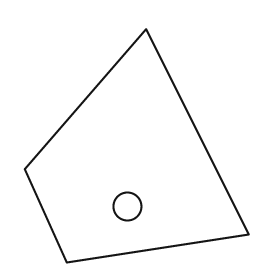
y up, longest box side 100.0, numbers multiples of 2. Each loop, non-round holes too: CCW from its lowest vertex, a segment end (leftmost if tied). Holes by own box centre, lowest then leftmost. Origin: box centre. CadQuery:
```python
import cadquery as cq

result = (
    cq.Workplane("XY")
    .moveTo(-30.0, -50.0)
    .lineTo(48.0, -38.0)
    .lineTo(4.0, 50.0)
    .lineTo(-48.0, -10.0)
    .close()
    .moveTo(-4.0, -26.0)
    .circle(6.0)
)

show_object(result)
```